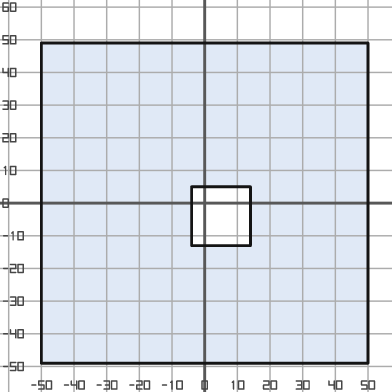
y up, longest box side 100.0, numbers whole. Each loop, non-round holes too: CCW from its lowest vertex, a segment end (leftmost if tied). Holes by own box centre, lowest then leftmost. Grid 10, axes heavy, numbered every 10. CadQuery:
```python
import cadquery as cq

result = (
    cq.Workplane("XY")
    .moveTo(-50.0, -49.0)
    .lineTo(50.0, -49.0)
    .lineTo(50.0, 49.0)
    .lineTo(-50.0, 49.0)
    .close()
    .moveTo(-4.0, -13.0)
    .lineTo(14.0, -13.0)
    .lineTo(14.0, 5.0)
    .lineTo(-4.0, 5.0)
    .close()
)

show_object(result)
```